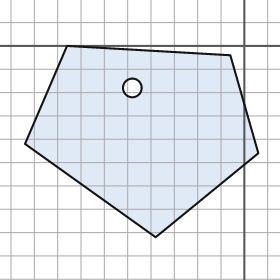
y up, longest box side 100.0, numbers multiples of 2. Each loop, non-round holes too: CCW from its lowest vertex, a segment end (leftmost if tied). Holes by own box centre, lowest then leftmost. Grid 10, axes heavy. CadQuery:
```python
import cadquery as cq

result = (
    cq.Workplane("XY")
    .moveTo(-38.0, -82.0)
    .lineTo(6.0, -46.0)
    .lineTo(-6.0, -4.0)
    .lineTo(-76.0, 0.0)
    .lineTo(-94.0, -42.0)
    .close()
    .moveTo(-48.0, -18.0)
    .circle(4.0)
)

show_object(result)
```